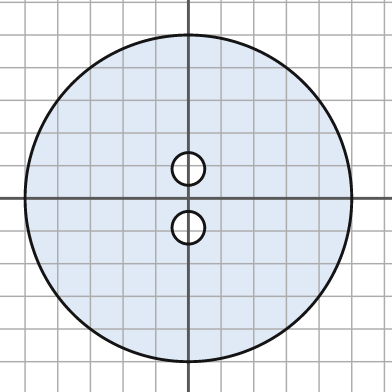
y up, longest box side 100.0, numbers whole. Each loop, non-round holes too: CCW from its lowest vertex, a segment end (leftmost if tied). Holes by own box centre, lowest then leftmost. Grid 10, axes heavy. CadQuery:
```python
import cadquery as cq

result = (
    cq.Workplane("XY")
    .moveTo(0.0, 0.0)
    .circle(50.0)
    .moveTo(0.0, -9.0)
    .circle(5.0)
    .moveTo(0.0, 9.0)
    .circle(5.0)
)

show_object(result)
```